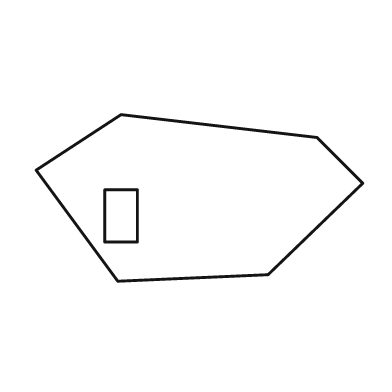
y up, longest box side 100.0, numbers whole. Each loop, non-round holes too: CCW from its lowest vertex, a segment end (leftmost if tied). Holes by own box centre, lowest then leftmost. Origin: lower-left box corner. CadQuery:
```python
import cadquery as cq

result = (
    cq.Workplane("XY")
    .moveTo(25.0, 0.0)
    .lineTo(71.0, 2.0)
    .lineTo(100.0, 30.0)
    .lineTo(86.0, 44.0)
    .lineTo(26.0, 51.0)
    .lineTo(0.0, 34.0)
    .close()
    .moveTo(21.0, 12.0)
    .lineTo(31.0, 12.0)
    .lineTo(31.0, 28.0)
    .lineTo(21.0, 28.0)
    .close()
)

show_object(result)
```